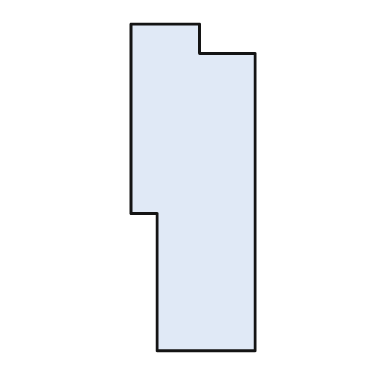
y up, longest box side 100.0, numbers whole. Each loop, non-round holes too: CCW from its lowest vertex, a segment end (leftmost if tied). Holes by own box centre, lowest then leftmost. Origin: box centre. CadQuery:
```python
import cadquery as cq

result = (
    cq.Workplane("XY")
    .moveTo(-11.0, -50.0)
    .lineTo(19.0, -50.0)
    .lineTo(19.0, 41.0)
    .lineTo(2.0, 41.0)
    .lineTo(2.0, 50.0)
    .lineTo(-19.0, 50.0)
    .lineTo(-19.0, -8.0)
    .lineTo(-11.0, -8.0)
    .close()
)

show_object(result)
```